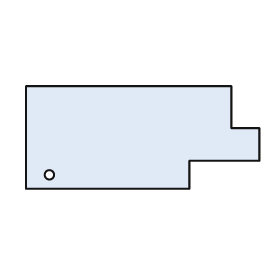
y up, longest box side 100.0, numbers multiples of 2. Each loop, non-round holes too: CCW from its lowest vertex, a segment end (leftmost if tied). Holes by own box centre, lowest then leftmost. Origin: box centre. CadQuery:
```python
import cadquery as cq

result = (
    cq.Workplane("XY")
    .moveTo(-50.0, -22.0)
    .lineTo(20.0, -22.0)
    .lineTo(20.0, -10.0)
    .lineTo(50.0, -10.0)
    .lineTo(50.0, 4.0)
    .lineTo(38.0, 4.0)
    .lineTo(38.0, 22.0)
    .lineTo(-50.0, 22.0)
    .close()
    .moveTo(-40.0, -16.0)
    .circle(2.0)
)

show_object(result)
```